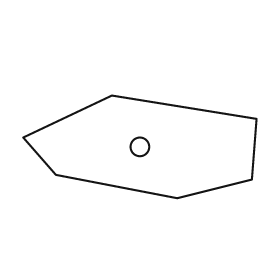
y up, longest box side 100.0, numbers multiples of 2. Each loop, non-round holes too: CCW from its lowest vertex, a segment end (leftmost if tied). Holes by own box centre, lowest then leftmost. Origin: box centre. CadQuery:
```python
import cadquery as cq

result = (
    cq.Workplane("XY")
    .moveTo(16.0, -22.0)
    .lineTo(48.0, -14.0)
    .lineTo(50.0, 12.0)
    .lineTo(-12.0, 22.0)
    .lineTo(-50.0, 4.0)
    .lineTo(-36.0, -12.0)
    .close()
    .moveTo(0.0, 0.0)
    .circle(4.0)
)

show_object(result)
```